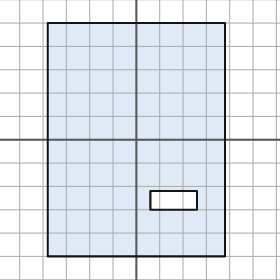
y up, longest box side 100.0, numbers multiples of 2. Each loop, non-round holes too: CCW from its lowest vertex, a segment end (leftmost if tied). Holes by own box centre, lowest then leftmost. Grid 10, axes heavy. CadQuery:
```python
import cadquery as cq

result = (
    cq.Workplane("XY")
    .moveTo(-38.0, -50.0)
    .lineTo(38.0, -50.0)
    .lineTo(38.0, 50.0)
    .lineTo(-38.0, 50.0)
    .close()
    .moveTo(6.0, -30.0)
    .lineTo(26.0, -30.0)
    .lineTo(26.0, -22.0)
    .lineTo(6.0, -22.0)
    .close()
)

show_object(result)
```